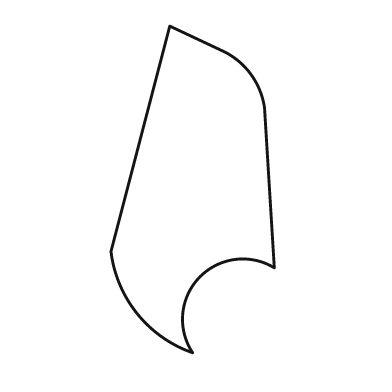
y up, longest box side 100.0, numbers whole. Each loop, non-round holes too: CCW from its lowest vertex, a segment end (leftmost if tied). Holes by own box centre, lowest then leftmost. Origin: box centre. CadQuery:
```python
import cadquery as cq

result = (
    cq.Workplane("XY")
    .moveTo(0.0, -50.0)
    .threePointArc((2.0, -27.0), (25.0, -24.0))
    .lineTo(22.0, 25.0)
    .threePointArc((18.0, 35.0), (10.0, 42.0))
    .lineTo(-7.0, 50.0)
    .lineTo(-25.0, -19.0)
    .threePointArc((-17.0, -38.0), (0.0, -50.0))
    .close()
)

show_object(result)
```